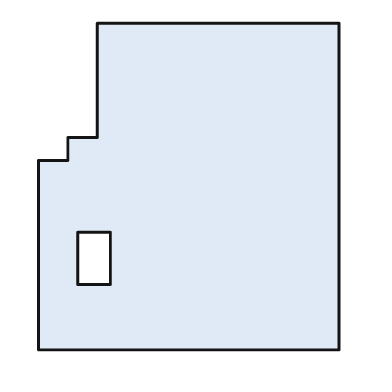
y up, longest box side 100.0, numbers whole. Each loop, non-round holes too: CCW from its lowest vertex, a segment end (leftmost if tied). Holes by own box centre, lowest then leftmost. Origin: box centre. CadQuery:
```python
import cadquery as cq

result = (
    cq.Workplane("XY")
    .moveTo(-46.0, -50.0)
    .lineTo(46.0, -50.0)
    .lineTo(46.0, 50.0)
    .lineTo(-28.0, 50.0)
    .lineTo(-28.0, 15.0)
    .lineTo(-37.0, 15.0)
    .lineTo(-37.0, 8.0)
    .lineTo(-46.0, 8.0)
    .close()
    .moveTo(-34.0, -30.0)
    .lineTo(-24.0, -30.0)
    .lineTo(-24.0, -14.0)
    .lineTo(-34.0, -14.0)
    .close()
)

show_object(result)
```